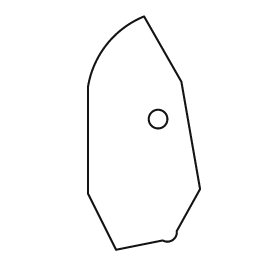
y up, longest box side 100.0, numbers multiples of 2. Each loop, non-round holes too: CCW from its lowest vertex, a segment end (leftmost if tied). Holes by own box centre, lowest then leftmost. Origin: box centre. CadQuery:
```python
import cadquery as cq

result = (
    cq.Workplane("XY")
    .moveTo(-12.0, -50.0)
    .lineTo(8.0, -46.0)
    .threePointArc((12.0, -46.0), (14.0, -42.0))
    .lineTo(24.0, -24.0)
    .lineTo(16.0, 22.0)
    .lineTo(0.0, 50.0)
    .threePointArc((-16.0, 38.0), (-24.0, 20.0))
    .lineTo(-24.0, -26.0)
    .close()
    .moveTo(6.0, 6.0)
    .circle(4.0)
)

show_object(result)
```